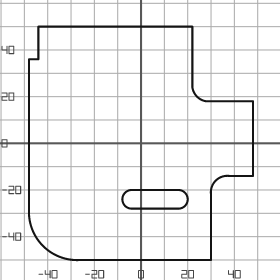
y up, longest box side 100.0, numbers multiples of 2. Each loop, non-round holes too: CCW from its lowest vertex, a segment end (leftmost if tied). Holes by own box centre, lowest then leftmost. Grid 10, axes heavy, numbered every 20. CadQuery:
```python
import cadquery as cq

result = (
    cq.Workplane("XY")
    .moveTo(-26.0, -50.0)
    .lineTo(30.0, -50.0)
    .lineTo(30.0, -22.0)
    .threePointArc((32.0, -16.0), (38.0, -14.0))
    .lineTo(48.0, -14.0)
    .lineTo(48.0, 18.0)
    .lineTo(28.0, 18.0)
    .threePointArc((24.0, 20.0), (22.0, 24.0))
    .lineTo(22.0, 50.0)
    .lineTo(-44.0, 50.0)
    .lineTo(-44.0, 36.0)
    .lineTo(-48.0, 36.0)
    .lineTo(-48.0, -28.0)
    .threePointArc((-42.0, -44.0), (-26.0, -50.0))
    .close()
    .moveTo(-4.0, -28.0)
    .lineTo(16.0, -28.0)
    .threePointArc((20.0, -24.0), (16.0, -20.0))
    .lineTo(-4.0, -20.0)
    .threePointArc((-8.0, -24.0), (-4.0, -28.0))
    .close()
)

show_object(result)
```